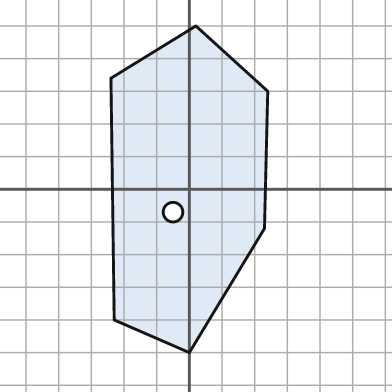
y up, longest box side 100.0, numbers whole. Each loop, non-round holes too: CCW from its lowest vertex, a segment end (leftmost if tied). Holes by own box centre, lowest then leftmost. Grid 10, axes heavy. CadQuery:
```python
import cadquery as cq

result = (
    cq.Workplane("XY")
    .moveTo(0.0, -50.0)
    .lineTo(23.0, -12.0)
    .lineTo(24.0, 30.0)
    .lineTo(2.0, 50.0)
    .lineTo(-24.0, 34.0)
    .lineTo(-23.0, -40.0)
    .close()
    .moveTo(-5.0, -7.0)
    .circle(3.0)
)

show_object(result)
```